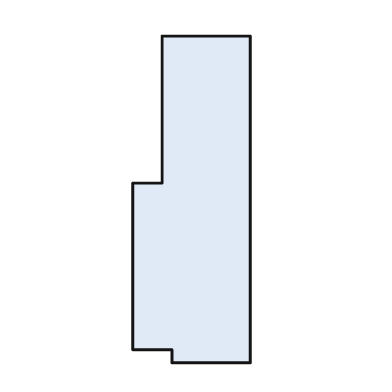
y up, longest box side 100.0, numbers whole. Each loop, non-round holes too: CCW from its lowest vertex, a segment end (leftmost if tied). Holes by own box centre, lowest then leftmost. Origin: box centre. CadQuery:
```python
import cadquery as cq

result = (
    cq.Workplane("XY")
    .moveTo(-6.0, -50.0)
    .lineTo(18.0, -50.0)
    .lineTo(18.0, 50.0)
    .lineTo(-9.0, 50.0)
    .lineTo(-9.0, 5.0)
    .lineTo(-18.0, 5.0)
    .lineTo(-18.0, -46.0)
    .lineTo(-6.0, -46.0)
    .close()
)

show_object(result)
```